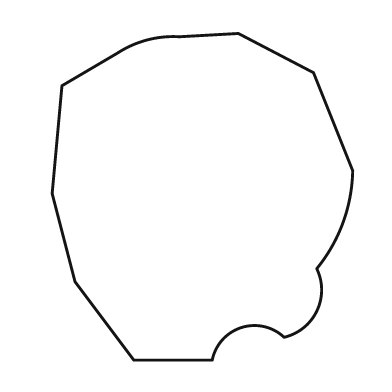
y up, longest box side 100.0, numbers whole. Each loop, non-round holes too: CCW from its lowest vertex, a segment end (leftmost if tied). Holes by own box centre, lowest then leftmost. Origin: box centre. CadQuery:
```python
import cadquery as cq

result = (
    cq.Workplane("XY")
    .moveTo(-21.0, -50.0)
    .lineTo(3.0, -50.0)
    .threePointArc((12.0, -40.0), (25.0, -43.0))
    .threePointArc((35.0, -35.0), (35.0, -22.0))
    .threePointArc((43.0, -8.0), (46.0, 8.0))
    .lineTo(34.0, 38.0)
    .lineTo(11.0, 50.0)
    .lineTo(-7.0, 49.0)
    .threePointArc((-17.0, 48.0), (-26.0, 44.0))
    .lineTo(-43.0, 34.0)
    .lineTo(-46.0, 1.0)
    .lineTo(-39.0, -26.0)
    .close()
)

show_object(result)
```